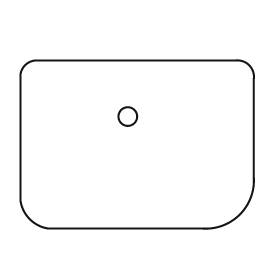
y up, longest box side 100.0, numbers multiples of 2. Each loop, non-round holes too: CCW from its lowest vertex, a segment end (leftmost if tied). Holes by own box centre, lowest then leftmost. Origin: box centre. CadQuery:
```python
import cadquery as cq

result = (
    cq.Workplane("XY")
    .moveTo(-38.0, -36.0)
    .lineTo(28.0, -36.0)
    .threePointArc((44.0, -30.0), (50.0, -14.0))
    .lineTo(50.0, 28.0)
    .threePointArc((48.0, 34.0), (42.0, 36.0))
    .lineTo(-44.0, 36.0)
    .threePointArc((-48.0, 34.0), (-50.0, 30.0))
    .lineTo(-50.0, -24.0)
    .threePointArc((-46.0, -32.0), (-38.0, -36.0))
    .close()
    .moveTo(-4.0, 12.0)
    .circle(4.0)
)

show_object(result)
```